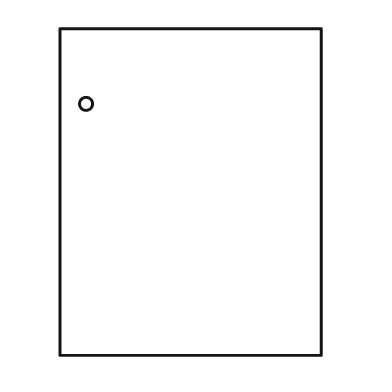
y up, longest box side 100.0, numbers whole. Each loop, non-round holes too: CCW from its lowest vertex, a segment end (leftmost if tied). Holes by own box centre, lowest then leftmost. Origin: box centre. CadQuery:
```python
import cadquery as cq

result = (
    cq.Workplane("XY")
    .moveTo(-40.0, -50.0)
    .lineTo(40.0, -50.0)
    .lineTo(40.0, 50.0)
    .lineTo(-40.0, 50.0)
    .close()
    .moveTo(-32.0, 27.0)
    .circle(2.0)
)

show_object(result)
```